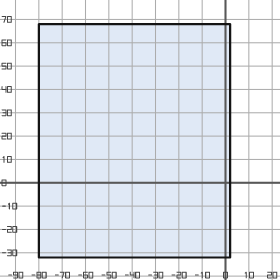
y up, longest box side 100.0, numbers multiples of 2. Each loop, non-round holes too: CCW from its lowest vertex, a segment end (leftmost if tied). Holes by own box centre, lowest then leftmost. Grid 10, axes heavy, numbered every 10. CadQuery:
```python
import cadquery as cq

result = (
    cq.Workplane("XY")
    .moveTo(-80.0, -32.0)
    .lineTo(2.0, -32.0)
    .lineTo(2.0, 68.0)
    .lineTo(-80.0, 68.0)
    .close()
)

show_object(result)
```